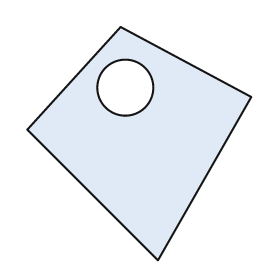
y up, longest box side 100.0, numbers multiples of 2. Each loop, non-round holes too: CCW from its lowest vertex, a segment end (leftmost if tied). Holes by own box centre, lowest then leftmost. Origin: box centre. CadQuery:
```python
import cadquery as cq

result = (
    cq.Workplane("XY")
    .moveTo(8.0, -50.0)
    .lineTo(48.0, 20.0)
    .lineTo(-8.0, 50.0)
    .lineTo(-48.0, 6.0)
    .close()
    .moveTo(-6.0, 24.0)
    .circle(12.0)
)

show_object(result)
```